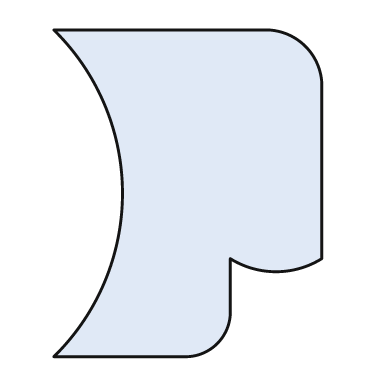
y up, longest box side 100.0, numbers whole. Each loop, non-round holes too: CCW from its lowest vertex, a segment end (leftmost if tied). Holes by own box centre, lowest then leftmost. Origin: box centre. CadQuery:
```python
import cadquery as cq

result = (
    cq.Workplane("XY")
    .moveTo(-41.0, -50.0)
    .lineTo(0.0, -50.0)
    .threePointArc((9.0, -46.0), (13.0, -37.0))
    .lineTo(13.0, -20.0)
    .threePointArc((27.0, -24.0), (41.0, -20.0))
    .lineTo(41.0, 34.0)
    .threePointArc((36.0, 45.0), (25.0, 50.0))
    .lineTo(-41.0, 50.0)
    .threePointArc((-20.0, 0.0), (-41.0, -50.0))
    .close()
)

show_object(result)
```